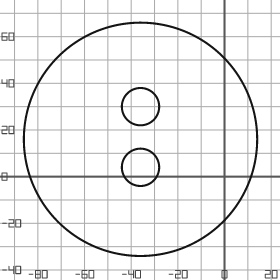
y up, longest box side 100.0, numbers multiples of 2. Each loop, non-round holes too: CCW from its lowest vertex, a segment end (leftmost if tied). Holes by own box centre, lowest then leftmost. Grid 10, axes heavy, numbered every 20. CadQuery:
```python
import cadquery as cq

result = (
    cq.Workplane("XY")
    .moveTo(-36.0, 16.0)
    .circle(50.0)
    .moveTo(-36.0, 4.0)
    .circle(8.0)
    .moveTo(-36.0, 30.0)
    .circle(8.0)
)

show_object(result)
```